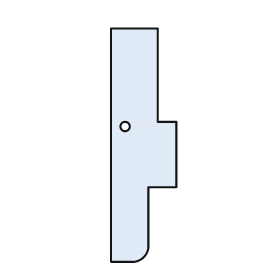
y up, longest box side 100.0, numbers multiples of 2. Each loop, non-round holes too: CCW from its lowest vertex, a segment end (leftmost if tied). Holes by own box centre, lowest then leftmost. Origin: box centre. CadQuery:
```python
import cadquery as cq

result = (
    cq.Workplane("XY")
    .moveTo(-14.0, -50.0)
    .lineTo(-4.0, -50.0)
    .threePointArc((0.0, -48.0), (2.0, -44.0))
    .lineTo(2.0, -18.0)
    .lineTo(14.0, -18.0)
    .lineTo(14.0, 10.0)
    .lineTo(6.0, 10.0)
    .lineTo(6.0, 50.0)
    .lineTo(-14.0, 50.0)
    .close()
    .moveTo(-8.0, 8.0)
    .circle(2.0)
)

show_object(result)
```